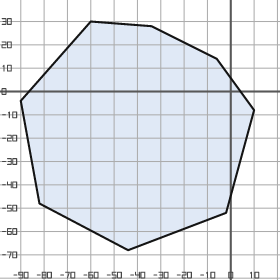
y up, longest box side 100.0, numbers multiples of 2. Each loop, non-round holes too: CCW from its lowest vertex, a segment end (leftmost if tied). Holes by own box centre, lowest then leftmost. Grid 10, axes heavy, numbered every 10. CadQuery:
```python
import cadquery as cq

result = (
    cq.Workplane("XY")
    .moveTo(-44.0, -68.0)
    .lineTo(-2.0, -52.0)
    .lineTo(10.0, -8.0)
    .lineTo(-6.0, 14.0)
    .lineTo(-34.0, 28.0)
    .lineTo(-60.0, 30.0)
    .lineTo(-90.0, -4.0)
    .lineTo(-82.0, -48.0)
    .close()
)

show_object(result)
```